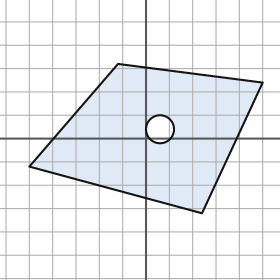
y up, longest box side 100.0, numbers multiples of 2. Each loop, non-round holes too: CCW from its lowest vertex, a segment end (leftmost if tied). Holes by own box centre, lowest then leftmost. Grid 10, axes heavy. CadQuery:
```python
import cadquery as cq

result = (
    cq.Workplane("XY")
    .moveTo(24.0, -32.0)
    .lineTo(50.0, 24.0)
    .lineTo(-12.0, 32.0)
    .lineTo(-50.0, -12.0)
    .close()
    .moveTo(6.0, 4.0)
    .circle(6.0)
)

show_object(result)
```